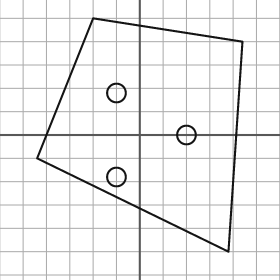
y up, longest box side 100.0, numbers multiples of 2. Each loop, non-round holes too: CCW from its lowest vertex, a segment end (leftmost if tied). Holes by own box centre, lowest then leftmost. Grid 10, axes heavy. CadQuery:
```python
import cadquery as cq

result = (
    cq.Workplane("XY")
    .moveTo(38.0, -50.0)
    .lineTo(44.0, 40.0)
    .lineTo(-20.0, 50.0)
    .lineTo(-44.0, -10.0)
    .close()
    .moveTo(-10.0, -18.0)
    .circle(4.0)
    .moveTo(20.0, 0.0)
    .circle(4.0)
    .moveTo(-10.0, 18.0)
    .circle(4.0)
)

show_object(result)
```